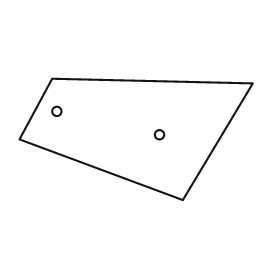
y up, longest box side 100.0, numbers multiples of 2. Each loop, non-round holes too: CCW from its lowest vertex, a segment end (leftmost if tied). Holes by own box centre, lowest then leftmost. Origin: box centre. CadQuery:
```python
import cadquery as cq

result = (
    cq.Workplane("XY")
    .moveTo(20.0, -26.0)
    .lineTo(50.0, 24.0)
    .lineTo(-36.0, 26.0)
    .lineTo(-50.0, 0.0)
    .close()
    .moveTo(10.0, 2.0)
    .circle(2.0)
    .moveTo(-34.0, 12.0)
    .circle(2.0)
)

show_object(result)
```